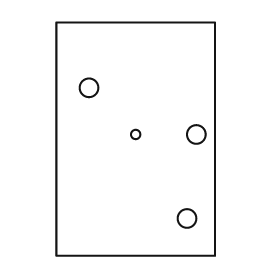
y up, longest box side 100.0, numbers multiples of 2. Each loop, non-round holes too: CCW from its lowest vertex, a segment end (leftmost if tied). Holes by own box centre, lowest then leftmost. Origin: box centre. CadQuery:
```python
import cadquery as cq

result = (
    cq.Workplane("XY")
    .moveTo(-34.0, -50.0)
    .lineTo(34.0, -50.0)
    .lineTo(34.0, 50.0)
    .lineTo(-34.0, 50.0)
    .close()
    .moveTo(22.0, -34.0)
    .circle(4.0)
    .moveTo(0.0, 2.0)
    .circle(2.0)
    .moveTo(26.0, 2.0)
    .circle(4.0)
    .moveTo(-20.0, 22.0)
    .circle(4.0)
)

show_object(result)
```